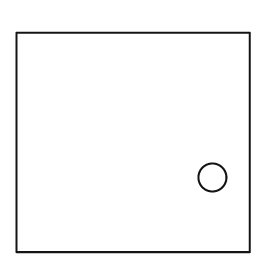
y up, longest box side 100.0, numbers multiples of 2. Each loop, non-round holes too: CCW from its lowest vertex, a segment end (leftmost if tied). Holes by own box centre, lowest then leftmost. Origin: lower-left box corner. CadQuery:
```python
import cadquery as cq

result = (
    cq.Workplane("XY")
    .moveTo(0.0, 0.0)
    .lineTo(100.0, 0.0)
    .lineTo(100.0, 94.0)
    .lineTo(0.0, 94.0)
    .close()
    .moveTo(84.0, 32.0)
    .circle(6.0)
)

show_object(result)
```